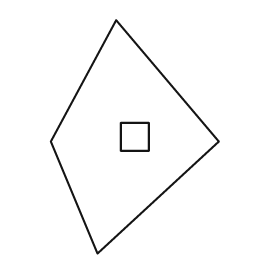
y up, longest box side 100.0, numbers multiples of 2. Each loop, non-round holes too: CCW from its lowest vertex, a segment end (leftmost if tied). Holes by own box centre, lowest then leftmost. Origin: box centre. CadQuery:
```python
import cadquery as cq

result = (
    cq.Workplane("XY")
    .moveTo(-16.0, -50.0)
    .lineTo(36.0, -2.0)
    .lineTo(-8.0, 50.0)
    .lineTo(-36.0, -2.0)
    .close()
    .moveTo(-6.0, -6.0)
    .lineTo(6.0, -6.0)
    .lineTo(6.0, 6.0)
    .lineTo(-6.0, 6.0)
    .close()
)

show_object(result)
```